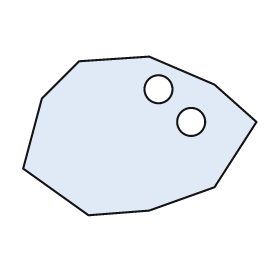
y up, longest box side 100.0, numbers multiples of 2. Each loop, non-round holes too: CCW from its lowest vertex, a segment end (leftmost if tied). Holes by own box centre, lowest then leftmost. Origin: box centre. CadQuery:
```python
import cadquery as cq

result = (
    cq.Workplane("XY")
    .moveTo(-22.0, -34.0)
    .lineTo(4.0, -32.0)
    .lineTo(32.0, -22.0)
    .lineTo(50.0, 6.0)
    .lineTo(32.0, 22.0)
    .lineTo(4.0, 34.0)
    .lineTo(-26.0, 32.0)
    .lineTo(-42.0, 16.0)
    .lineTo(-50.0, -14.0)
    .close()
    .moveTo(22.0, 6.0)
    .circle(6.0)
    .moveTo(8.0, 20.0)
    .circle(6.0)
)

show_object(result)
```